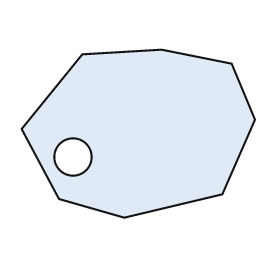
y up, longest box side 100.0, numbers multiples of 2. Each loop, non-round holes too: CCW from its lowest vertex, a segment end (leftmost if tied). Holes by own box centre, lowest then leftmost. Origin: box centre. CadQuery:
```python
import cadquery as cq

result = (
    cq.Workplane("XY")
    .moveTo(-6.0, -36.0)
    .lineTo(36.0, -26.0)
    .lineTo(50.0, 6.0)
    .lineTo(40.0, 30.0)
    .lineTo(10.0, 36.0)
    .lineTo(-24.0, 34.0)
    .lineTo(-50.0, 2.0)
    .lineTo(-34.0, -28.0)
    .close()
    .moveTo(-28.0, -10.0)
    .circle(8.0)
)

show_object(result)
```